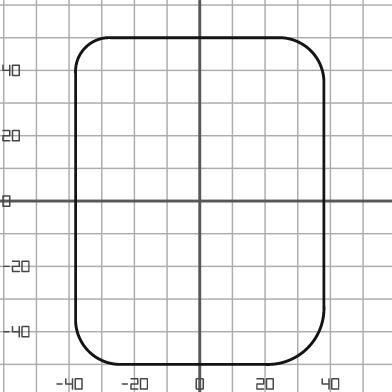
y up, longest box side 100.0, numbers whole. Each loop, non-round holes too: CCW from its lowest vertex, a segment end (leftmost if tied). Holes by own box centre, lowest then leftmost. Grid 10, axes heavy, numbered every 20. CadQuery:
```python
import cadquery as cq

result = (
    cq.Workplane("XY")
    .moveTo(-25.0, -50.0)
    .lineTo(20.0, -50.0)
    .threePointArc((33.0, -45.0), (38.0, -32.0))
    .lineTo(38.0, 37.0)
    .threePointArc((34.0, 46.0), (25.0, 50.0))
    .lineTo(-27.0, 50.0)
    .threePointArc((-35.0, 47.0), (-38.0, 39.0))
    .lineTo(-38.0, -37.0)
    .threePointArc((-34.0, -46.0), (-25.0, -50.0))
    .close()
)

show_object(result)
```